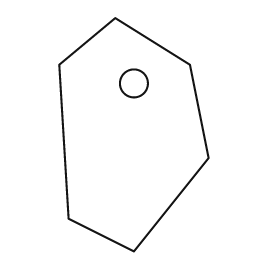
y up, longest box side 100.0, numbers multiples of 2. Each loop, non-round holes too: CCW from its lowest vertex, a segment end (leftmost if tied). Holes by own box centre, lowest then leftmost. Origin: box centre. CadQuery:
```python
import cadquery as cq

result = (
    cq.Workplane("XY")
    .moveTo(0.0, -50.0)
    .lineTo(32.0, -10.0)
    .lineTo(24.0, 30.0)
    .lineTo(-8.0, 50.0)
    .lineTo(-32.0, 30.0)
    .lineTo(-28.0, -36.0)
    .close()
    .moveTo(0.0, 22.0)
    .circle(6.0)
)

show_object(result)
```